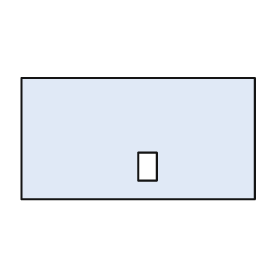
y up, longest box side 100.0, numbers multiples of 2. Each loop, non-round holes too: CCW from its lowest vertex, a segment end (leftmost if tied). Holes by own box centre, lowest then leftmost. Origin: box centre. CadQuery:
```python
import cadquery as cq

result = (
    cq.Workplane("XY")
    .moveTo(-50.0, -26.0)
    .lineTo(50.0, -26.0)
    .lineTo(50.0, 26.0)
    .lineTo(-50.0, 26.0)
    .close()
    .moveTo(0.0, -18.0)
    .lineTo(8.0, -18.0)
    .lineTo(8.0, -6.0)
    .lineTo(0.0, -6.0)
    .close()
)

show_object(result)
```